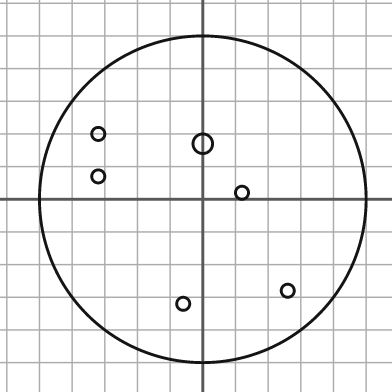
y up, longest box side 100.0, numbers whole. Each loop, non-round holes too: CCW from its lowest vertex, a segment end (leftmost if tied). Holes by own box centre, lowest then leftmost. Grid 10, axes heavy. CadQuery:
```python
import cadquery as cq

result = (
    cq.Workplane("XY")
    .moveTo(0.0, 0.0)
    .circle(50.0)
    .moveTo(-6.0, -32.0)
    .circle(2.0)
    .moveTo(26.0, -28.0)
    .circle(2.0)
    .moveTo(12.0, 2.0)
    .circle(2.0)
    .moveTo(-32.0, 7.0)
    .circle(2.0)
    .moveTo(0.0, 17.0)
    .circle(3.0)
    .moveTo(-32.0, 20.0)
    .circle(2.0)
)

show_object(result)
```